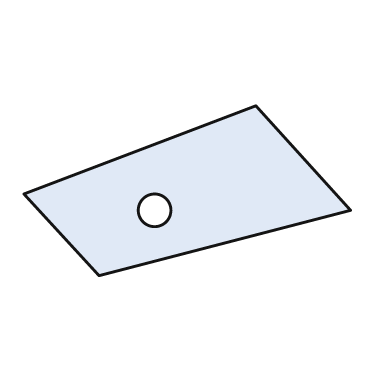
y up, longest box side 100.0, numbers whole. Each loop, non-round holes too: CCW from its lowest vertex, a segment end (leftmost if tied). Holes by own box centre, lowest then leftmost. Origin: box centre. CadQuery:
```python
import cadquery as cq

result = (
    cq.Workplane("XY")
    .moveTo(-27.0, -26.0)
    .lineTo(50.0, -6.0)
    .lineTo(21.0, 26.0)
    .lineTo(-50.0, -1.0)
    .close()
    .moveTo(-10.0, -6.0)
    .circle(5.0)
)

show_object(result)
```